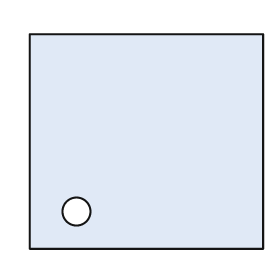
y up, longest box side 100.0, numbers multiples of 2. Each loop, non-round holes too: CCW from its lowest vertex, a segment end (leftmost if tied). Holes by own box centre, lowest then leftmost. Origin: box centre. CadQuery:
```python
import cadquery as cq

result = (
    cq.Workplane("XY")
    .moveTo(-50.0, -46.0)
    .lineTo(50.0, -46.0)
    .lineTo(50.0, 46.0)
    .lineTo(-50.0, 46.0)
    .close()
    .moveTo(-30.0, -30.0)
    .circle(6.0)
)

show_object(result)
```